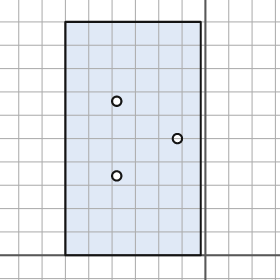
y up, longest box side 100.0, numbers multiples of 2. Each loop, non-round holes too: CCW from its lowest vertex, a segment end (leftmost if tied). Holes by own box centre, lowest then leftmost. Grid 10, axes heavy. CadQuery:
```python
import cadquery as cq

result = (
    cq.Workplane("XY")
    .moveTo(-60.0, 0.0)
    .lineTo(-2.0, 0.0)
    .lineTo(-2.0, 100.0)
    .lineTo(-60.0, 100.0)
    .close()
    .moveTo(-38.0, 34.0)
    .circle(2.0)
    .moveTo(-12.0, 50.0)
    .circle(2.0)
    .moveTo(-38.0, 66.0)
    .circle(2.0)
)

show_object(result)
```